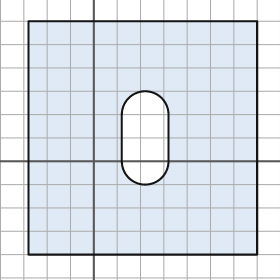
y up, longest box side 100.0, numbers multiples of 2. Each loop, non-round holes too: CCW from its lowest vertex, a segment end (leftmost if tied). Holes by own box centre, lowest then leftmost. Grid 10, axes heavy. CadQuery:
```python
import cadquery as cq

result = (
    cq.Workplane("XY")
    .moveTo(-28.0, -40.0)
    .lineTo(70.0, -40.0)
    .lineTo(70.0, 60.0)
    .lineTo(-28.0, 60.0)
    .close()
    .moveTo(12.0, 0.0)
    .threePointArc((22.0, -10.0), (32.0, 0.0))
    .lineTo(32.0, 20.0)
    .threePointArc((22.0, 30.0), (12.0, 20.0))
    .close()
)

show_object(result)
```